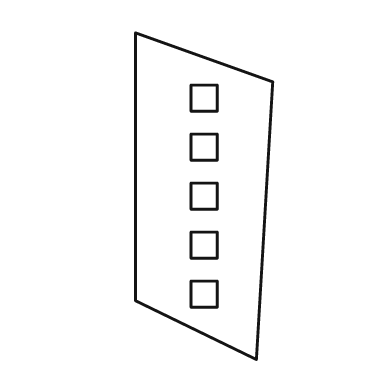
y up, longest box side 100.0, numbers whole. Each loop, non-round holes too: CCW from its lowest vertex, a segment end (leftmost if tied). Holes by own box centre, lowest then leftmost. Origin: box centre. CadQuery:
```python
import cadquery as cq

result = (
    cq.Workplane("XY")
    .moveTo(16.0, -50.0)
    .lineTo(21.0, 35.0)
    .lineTo(-21.0, 50.0)
    .lineTo(-21.0, -32.0)
    .close()
    .moveTo(-4.0, -34.0)
    .lineTo(4.0, -34.0)
    .lineTo(4.0, -26.0)
    .lineTo(-4.0, -26.0)
    .close()
    .moveTo(-4.0, -19.0)
    .lineTo(4.0, -19.0)
    .lineTo(4.0, -11.0)
    .lineTo(-4.0, -11.0)
    .close()
    .moveTo(-4.0, -4.0)
    .lineTo(4.0, -4.0)
    .lineTo(4.0, 4.0)
    .lineTo(-4.0, 4.0)
    .close()
    .moveTo(-4.0, 11.0)
    .lineTo(4.0, 11.0)
    .lineTo(4.0, 19.0)
    .lineTo(-4.0, 19.0)
    .close()
    .moveTo(-4.0, 26.0)
    .lineTo(4.0, 26.0)
    .lineTo(4.0, 34.0)
    .lineTo(-4.0, 34.0)
    .close()
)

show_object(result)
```